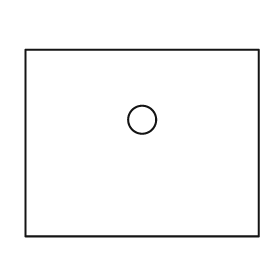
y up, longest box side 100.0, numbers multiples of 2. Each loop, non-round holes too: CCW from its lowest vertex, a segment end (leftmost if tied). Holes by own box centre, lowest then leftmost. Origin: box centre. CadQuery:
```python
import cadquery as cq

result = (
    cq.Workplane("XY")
    .moveTo(-50.0, -40.0)
    .lineTo(50.0, -40.0)
    .lineTo(50.0, 40.0)
    .lineTo(-50.0, 40.0)
    .close()
    .moveTo(0.0, 10.0)
    .circle(6.0)
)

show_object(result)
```